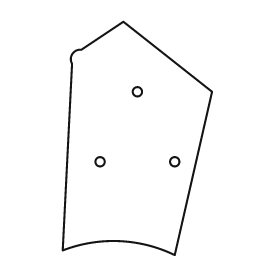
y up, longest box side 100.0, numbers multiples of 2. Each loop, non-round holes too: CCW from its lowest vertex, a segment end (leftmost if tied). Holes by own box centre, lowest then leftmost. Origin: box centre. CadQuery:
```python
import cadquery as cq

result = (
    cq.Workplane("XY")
    .moveTo(16.0, -50.0)
    .lineTo(32.0, 20.0)
    .lineTo(-6.0, 50.0)
    .lineTo(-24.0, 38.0)
    .threePointArc((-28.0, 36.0), (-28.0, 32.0))
    .lineTo(-32.0, -48.0)
    .threePointArc((-8.0, -44.0), (16.0, -50.0))
    .close()
    .moveTo(-16.0, -10.0)
    .circle(2.0)
    .moveTo(16.0, -10.0)
    .circle(2.0)
    .moveTo(0.0, 20.0)
    .circle(2.0)
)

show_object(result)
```